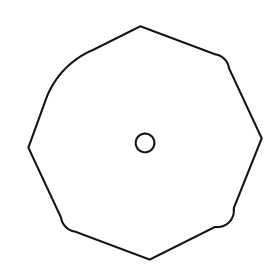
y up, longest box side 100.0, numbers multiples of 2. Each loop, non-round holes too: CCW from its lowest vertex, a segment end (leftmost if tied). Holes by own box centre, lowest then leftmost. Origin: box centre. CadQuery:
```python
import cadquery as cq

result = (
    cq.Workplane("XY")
    .moveTo(2.0, -50.0)
    .lineTo(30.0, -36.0)
    .threePointArc((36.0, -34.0), (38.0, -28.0))
    .lineTo(50.0, 2.0)
    .lineTo(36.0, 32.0)
    .threePointArc((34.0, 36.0), (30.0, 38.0))
    .lineTo(-2.0, 50.0)
    .lineTo(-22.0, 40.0)
    .threePointArc((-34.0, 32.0), (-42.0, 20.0))
    .lineTo(-50.0, -2.0)
    .lineTo(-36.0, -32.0)
    .threePointArc((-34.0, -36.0), (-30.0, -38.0))
    .close()
    .moveTo(0.0, 0.0)
    .circle(4.0)
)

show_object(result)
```